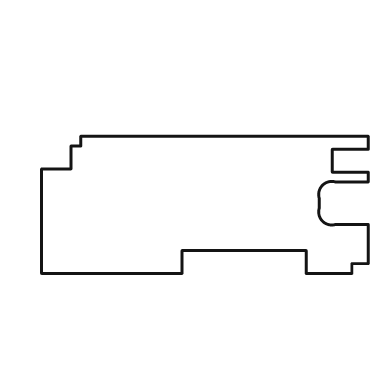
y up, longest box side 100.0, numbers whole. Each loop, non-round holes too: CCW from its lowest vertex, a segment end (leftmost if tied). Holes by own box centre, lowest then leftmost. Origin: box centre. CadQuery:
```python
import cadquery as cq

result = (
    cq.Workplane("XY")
    .moveTo(-50.0, -21.0)
    .lineTo(-7.0, -21.0)
    .lineTo(-7.0, -14.0)
    .lineTo(31.0, -14.0)
    .lineTo(31.0, -21.0)
    .lineTo(45.0, -21.0)
    .lineTo(45.0, -18.0)
    .lineTo(50.0, -18.0)
    .lineTo(50.0, -6.0)
    .lineTo(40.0, -6.0)
    .threePointArc((36.0, -5.0), (35.0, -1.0))
    .lineTo(35.0, 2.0)
    .threePointArc((36.0, 6.0), (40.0, 7.0))
    .lineTo(50.0, 7.0)
    .lineTo(50.0, 10.0)
    .lineTo(39.0, 10.0)
    .lineTo(39.0, 17.0)
    .lineTo(50.0, 17.0)
    .lineTo(50.0, 21.0)
    .lineTo(-38.0, 21.0)
    .lineTo(-38.0, 18.0)
    .lineTo(-41.0, 18.0)
    .lineTo(-41.0, 11.0)
    .lineTo(-50.0, 11.0)
    .close()
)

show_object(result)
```